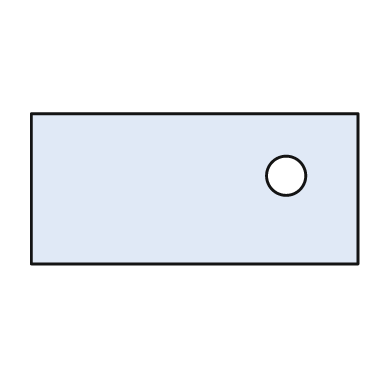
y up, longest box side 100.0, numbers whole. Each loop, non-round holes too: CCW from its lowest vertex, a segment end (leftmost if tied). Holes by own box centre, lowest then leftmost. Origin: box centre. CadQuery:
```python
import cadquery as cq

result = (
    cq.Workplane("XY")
    .moveTo(-50.0, -23.0)
    .lineTo(50.0, -23.0)
    .lineTo(50.0, 23.0)
    .lineTo(-50.0, 23.0)
    .close()
    .moveTo(28.0, 4.0)
    .circle(6.0)
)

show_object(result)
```